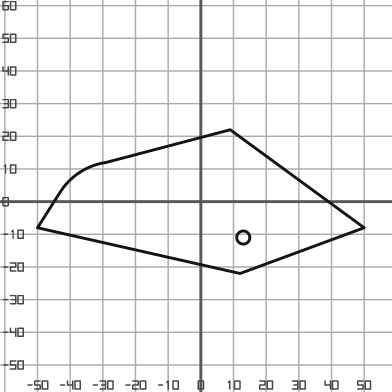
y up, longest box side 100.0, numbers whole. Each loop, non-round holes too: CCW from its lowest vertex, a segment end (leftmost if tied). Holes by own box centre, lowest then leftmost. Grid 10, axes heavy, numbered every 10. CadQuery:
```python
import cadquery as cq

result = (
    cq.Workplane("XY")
    .moveTo(12.0, -22.0)
    .lineTo(50.0, -8.0)
    .lineTo(9.0, 22.0)
    .lineTo(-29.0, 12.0)
    .threePointArc((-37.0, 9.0), (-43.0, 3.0))
    .lineTo(-50.0, -8.0)
    .close()
    .moveTo(13.0, -11.0)
    .circle(2.0)
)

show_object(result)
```